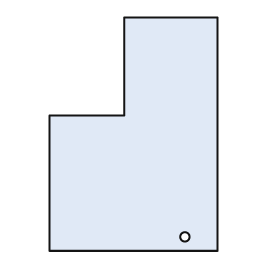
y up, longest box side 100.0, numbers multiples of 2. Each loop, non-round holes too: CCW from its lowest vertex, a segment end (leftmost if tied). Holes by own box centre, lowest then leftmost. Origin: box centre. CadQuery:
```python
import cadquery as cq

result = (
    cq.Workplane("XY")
    .moveTo(-36.0, -50.0)
    .lineTo(36.0, -50.0)
    .lineTo(36.0, 50.0)
    .lineTo(-4.0, 50.0)
    .lineTo(-4.0, 8.0)
    .lineTo(-36.0, 8.0)
    .close()
    .moveTo(22.0, -44.0)
    .circle(2.0)
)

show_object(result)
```